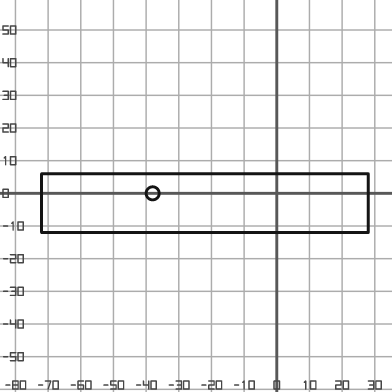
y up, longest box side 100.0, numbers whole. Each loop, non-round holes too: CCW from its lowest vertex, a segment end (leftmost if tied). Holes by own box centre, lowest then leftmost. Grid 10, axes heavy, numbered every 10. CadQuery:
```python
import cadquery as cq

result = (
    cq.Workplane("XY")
    .moveTo(-72.0, -12.0)
    .lineTo(28.0, -12.0)
    .lineTo(28.0, 6.0)
    .lineTo(-72.0, 6.0)
    .close()
    .moveTo(-38.0, 0.0)
    .circle(2.0)
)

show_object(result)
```